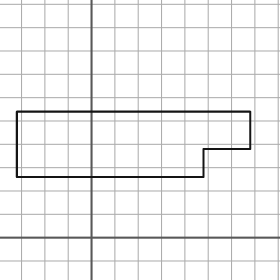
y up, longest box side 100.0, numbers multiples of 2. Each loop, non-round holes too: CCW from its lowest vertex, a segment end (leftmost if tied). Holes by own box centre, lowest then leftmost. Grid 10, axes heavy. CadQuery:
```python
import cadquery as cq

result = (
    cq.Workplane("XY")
    .moveTo(-32.0, 26.0)
    .lineTo(48.0, 26.0)
    .lineTo(48.0, 38.0)
    .lineTo(68.0, 38.0)
    .lineTo(68.0, 54.0)
    .lineTo(-32.0, 54.0)
    .close()
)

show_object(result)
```